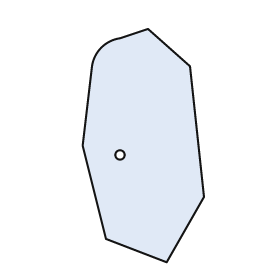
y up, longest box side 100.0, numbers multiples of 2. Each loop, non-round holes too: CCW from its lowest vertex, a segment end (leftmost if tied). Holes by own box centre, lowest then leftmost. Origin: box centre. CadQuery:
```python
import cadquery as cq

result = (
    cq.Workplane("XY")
    .moveTo(10.0, -50.0)
    .lineTo(26.0, -22.0)
    .lineTo(20.0, 34.0)
    .lineTo(2.0, 50.0)
    .lineTo(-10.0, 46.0)
    .threePointArc((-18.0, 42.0), (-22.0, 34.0))
    .lineTo(-26.0, 0.0)
    .lineTo(-16.0, -40.0)
    .close()
    .moveTo(-10.0, -4.0)
    .circle(2.0)
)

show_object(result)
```